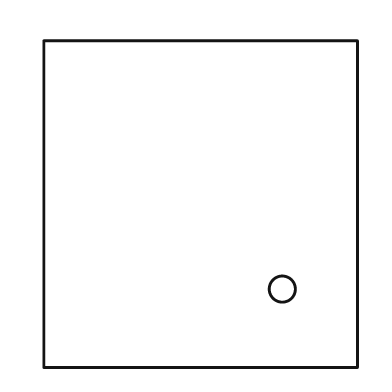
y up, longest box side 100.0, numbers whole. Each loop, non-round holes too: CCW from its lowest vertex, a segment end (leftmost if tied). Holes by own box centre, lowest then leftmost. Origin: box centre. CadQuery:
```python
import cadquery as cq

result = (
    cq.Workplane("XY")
    .moveTo(-48.0, -50.0)
    .lineTo(48.0, -50.0)
    .lineTo(48.0, 50.0)
    .lineTo(-48.0, 50.0)
    .close()
    .moveTo(25.0, -26.0)
    .circle(4.0)
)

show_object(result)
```